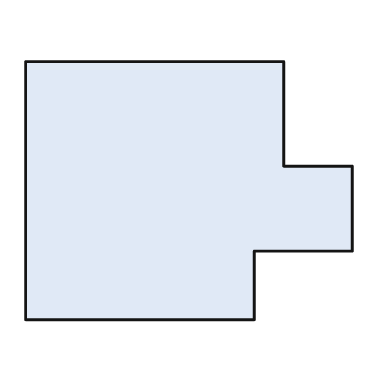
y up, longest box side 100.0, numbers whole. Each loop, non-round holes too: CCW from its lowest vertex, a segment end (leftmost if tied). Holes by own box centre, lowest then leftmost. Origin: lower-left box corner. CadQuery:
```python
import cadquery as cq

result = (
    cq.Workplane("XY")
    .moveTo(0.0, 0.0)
    .lineTo(70.0, 0.0)
    .lineTo(70.0, 21.0)
    .lineTo(100.0, 21.0)
    .lineTo(100.0, 47.0)
    .lineTo(79.0, 47.0)
    .lineTo(79.0, 79.0)
    .lineTo(0.0, 79.0)
    .close()
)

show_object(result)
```